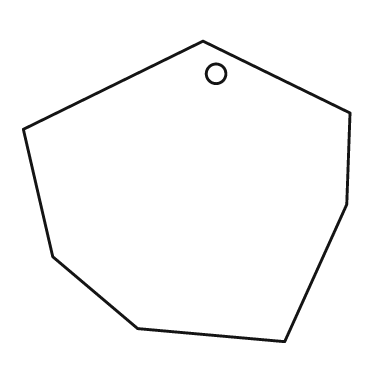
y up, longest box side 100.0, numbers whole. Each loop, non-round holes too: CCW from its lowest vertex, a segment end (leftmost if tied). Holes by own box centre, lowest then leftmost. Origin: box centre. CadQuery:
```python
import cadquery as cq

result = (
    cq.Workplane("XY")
    .moveTo(30.0, -46.0)
    .lineTo(49.0, -4.0)
    .lineTo(50.0, 24.0)
    .lineTo(5.0, 46.0)
    .lineTo(-50.0, 19.0)
    .lineTo(-41.0, -20.0)
    .lineTo(-15.0, -42.0)
    .close()
    .moveTo(9.0, 36.0)
    .circle(3.0)
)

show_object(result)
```